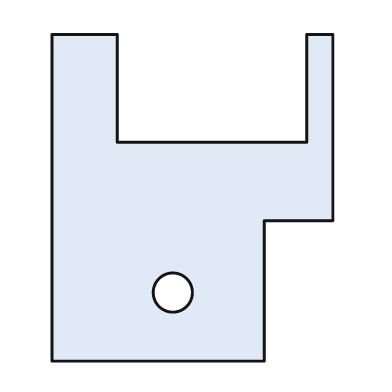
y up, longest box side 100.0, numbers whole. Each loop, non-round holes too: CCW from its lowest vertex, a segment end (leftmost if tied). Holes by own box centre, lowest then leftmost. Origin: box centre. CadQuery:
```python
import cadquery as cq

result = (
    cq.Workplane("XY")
    .moveTo(-43.0, -50.0)
    .lineTo(22.0, -50.0)
    .lineTo(22.0, -7.0)
    .lineTo(43.0, -7.0)
    .lineTo(43.0, 50.0)
    .lineTo(35.0, 50.0)
    .lineTo(35.0, 17.0)
    .lineTo(-23.0, 17.0)
    .lineTo(-23.0, 50.0)
    .lineTo(-43.0, 50.0)
    .close()
    .moveTo(-6.0, -29.0)
    .circle(6.0)
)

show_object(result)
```